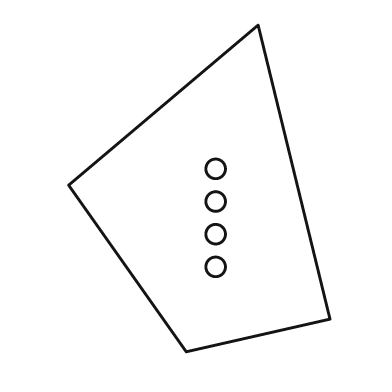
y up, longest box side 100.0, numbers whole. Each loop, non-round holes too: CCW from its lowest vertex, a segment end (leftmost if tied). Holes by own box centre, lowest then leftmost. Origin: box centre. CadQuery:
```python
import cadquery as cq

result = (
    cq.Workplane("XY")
    .moveTo(-4.0, -50.0)
    .lineTo(40.0, -40.0)
    .lineTo(18.0, 50.0)
    .lineTo(-40.0, 1.0)
    .close()
    .moveTo(5.0, -24.0)
    .circle(3.0)
    .moveTo(5.0, -14.0)
    .circle(3.0)
    .moveTo(5.0, -4.0)
    .circle(3.0)
    .moveTo(5.0, 6.0)
    .circle(3.0)
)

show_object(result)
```